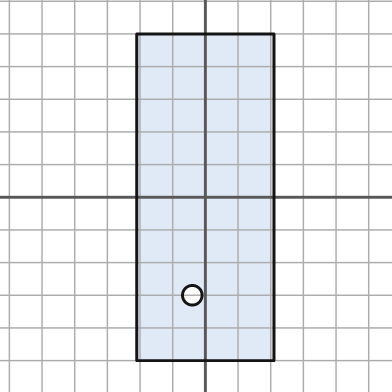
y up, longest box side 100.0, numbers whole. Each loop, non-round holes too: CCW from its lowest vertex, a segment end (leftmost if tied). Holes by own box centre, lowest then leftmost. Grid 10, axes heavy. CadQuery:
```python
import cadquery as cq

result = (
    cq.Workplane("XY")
    .moveTo(-21.0, -50.0)
    .lineTo(21.0, -50.0)
    .lineTo(21.0, 50.0)
    .lineTo(-21.0, 50.0)
    .close()
    .moveTo(-4.0, -30.0)
    .circle(3.0)
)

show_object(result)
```